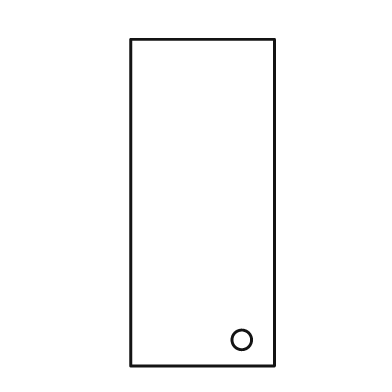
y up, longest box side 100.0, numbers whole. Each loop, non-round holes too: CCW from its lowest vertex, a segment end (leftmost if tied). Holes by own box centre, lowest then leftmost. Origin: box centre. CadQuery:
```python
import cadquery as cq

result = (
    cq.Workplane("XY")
    .moveTo(-22.0, -50.0)
    .lineTo(22.0, -50.0)
    .lineTo(22.0, 50.0)
    .lineTo(-22.0, 50.0)
    .close()
    .moveTo(12.0, -42.0)
    .circle(3.0)
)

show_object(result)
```